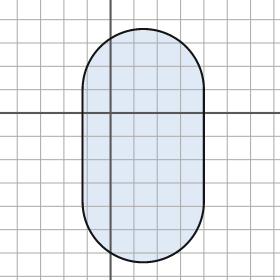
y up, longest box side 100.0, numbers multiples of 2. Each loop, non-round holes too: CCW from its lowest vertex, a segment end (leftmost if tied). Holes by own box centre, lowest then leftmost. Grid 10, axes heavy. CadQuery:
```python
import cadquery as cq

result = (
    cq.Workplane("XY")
    .moveTo(-12.0, -38.0)
    .threePointArc((14.0, -64.0), (40.0, -38.0))
    .lineTo(40.0, 10.0)
    .threePointArc((14.0, 36.0), (-12.0, 10.0))
    .close()
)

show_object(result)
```